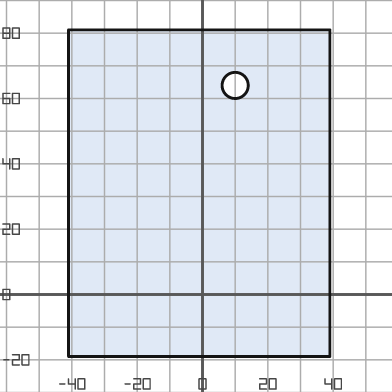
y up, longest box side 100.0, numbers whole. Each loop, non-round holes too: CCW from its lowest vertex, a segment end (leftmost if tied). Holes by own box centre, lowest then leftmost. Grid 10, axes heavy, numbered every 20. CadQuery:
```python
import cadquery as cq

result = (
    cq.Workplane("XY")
    .moveTo(-41.0, -19.0)
    .lineTo(39.0, -19.0)
    .lineTo(39.0, 81.0)
    .lineTo(-41.0, 81.0)
    .close()
    .moveTo(10.0, 64.0)
    .circle(4.0)
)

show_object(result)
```